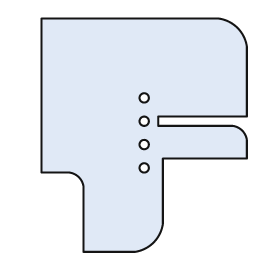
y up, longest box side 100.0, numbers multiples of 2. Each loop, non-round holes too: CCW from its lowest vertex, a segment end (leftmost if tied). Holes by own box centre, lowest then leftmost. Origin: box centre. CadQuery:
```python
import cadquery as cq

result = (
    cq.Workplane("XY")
    .moveTo(-26.0, -50.0)
    .lineTo(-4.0, -50.0)
    .threePointArc((4.0, -46.0), (8.0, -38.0))
    .lineTo(8.0, -10.0)
    .lineTo(44.0, -10.0)
    .lineTo(44.0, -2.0)
    .threePointArc((42.0, 2.0), (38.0, 4.0))
    .lineTo(6.0, 4.0)
    .lineTo(6.0, 8.0)
    .lineTo(44.0, 8.0)
    .lineTo(44.0, 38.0)
    .threePointArc((40.0, 46.0), (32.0, 50.0))
    .lineTo(-44.0, 50.0)
    .lineTo(-44.0, -16.0)
    .lineTo(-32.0, -16.0)
    .threePointArc((-28.0, -18.0), (-26.0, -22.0))
    .close()
    .moveTo(0.0, -14.0)
    .circle(2.0)
    .moveTo(0.0, -4.0)
    .circle(2.0)
    .moveTo(0.0, 6.0)
    .circle(2.0)
    .moveTo(0.0, 16.0)
    .circle(2.0)
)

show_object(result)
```